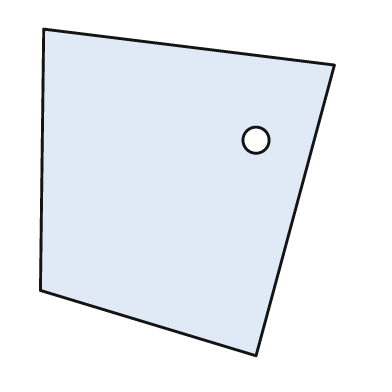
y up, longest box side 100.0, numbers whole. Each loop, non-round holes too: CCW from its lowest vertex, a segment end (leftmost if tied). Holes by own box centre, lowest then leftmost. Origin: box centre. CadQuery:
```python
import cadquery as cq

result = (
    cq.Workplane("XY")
    .moveTo(21.0, -50.0)
    .lineTo(45.0, 39.0)
    .lineTo(-44.0, 50.0)
    .lineTo(-45.0, -30.0)
    .close()
    .moveTo(21.0, 16.0)
    .circle(4.0)
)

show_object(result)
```